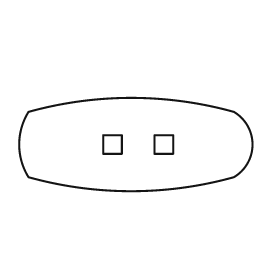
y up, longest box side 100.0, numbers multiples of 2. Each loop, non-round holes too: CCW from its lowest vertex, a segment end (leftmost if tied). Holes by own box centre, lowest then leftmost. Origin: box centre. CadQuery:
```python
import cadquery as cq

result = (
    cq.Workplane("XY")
    .moveTo(-46.0, -14.0)
    .threePointArc((-2.0, -20.0), (42.0, -14.0))
    .threePointArc((50.0, 0.0), (42.0, 14.0))
    .threePointArc((-2.0, 20.0), (-46.0, 14.0))
    .threePointArc((-50.0, 0.0), (-46.0, -14.0))
    .close()
    .moveTo(-14.0, -4.0)
    .lineTo(-6.0, -4.0)
    .lineTo(-6.0, 4.0)
    .lineTo(-14.0, 4.0)
    .close()
    .moveTo(8.0, -4.0)
    .lineTo(16.0, -4.0)
    .lineTo(16.0, 4.0)
    .lineTo(8.0, 4.0)
    .close()
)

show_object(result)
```